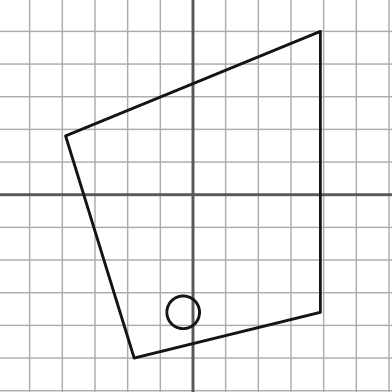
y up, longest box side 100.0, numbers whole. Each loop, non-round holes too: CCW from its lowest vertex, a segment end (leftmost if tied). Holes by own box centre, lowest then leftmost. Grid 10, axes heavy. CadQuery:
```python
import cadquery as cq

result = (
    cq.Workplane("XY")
    .moveTo(-18.0, -50.0)
    .lineTo(39.0, -36.0)
    .lineTo(39.0, 50.0)
    .lineTo(-39.0, 18.0)
    .close()
    .moveTo(-3.0, -36.0)
    .circle(5.0)
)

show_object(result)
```